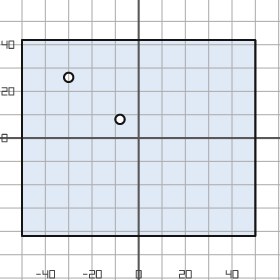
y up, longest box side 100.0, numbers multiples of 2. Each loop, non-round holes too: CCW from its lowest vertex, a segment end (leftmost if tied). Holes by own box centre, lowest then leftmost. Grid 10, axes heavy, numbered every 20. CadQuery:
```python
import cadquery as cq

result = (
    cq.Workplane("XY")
    .moveTo(-50.0, -42.0)
    .lineTo(50.0, -42.0)
    .lineTo(50.0, 42.0)
    .lineTo(-50.0, 42.0)
    .close()
    .moveTo(-8.0, 8.0)
    .circle(2.0)
    .moveTo(-30.0, 26.0)
    .circle(2.0)
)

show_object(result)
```